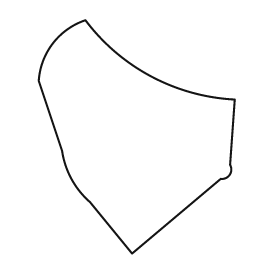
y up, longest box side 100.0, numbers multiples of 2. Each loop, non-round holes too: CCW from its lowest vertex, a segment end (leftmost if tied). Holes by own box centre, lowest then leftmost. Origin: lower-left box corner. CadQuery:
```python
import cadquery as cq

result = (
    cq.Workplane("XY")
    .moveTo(40.0, 0.0)
    .lineTo(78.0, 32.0)
    .threePointArc((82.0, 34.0), (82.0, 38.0))
    .lineTo(84.0, 66.0)
    .threePointArc((48.0, 76.0), (20.0, 100.0))
    .threePointArc((6.0, 90.0), (0.0, 74.0))
    .lineTo(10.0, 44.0)
    .threePointArc((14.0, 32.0), (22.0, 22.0))
    .close()
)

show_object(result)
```